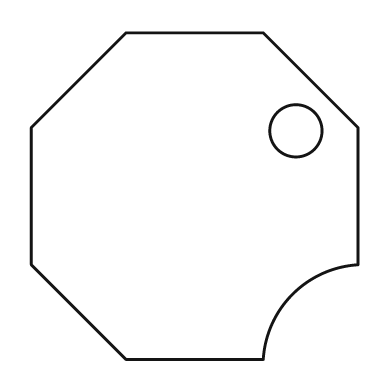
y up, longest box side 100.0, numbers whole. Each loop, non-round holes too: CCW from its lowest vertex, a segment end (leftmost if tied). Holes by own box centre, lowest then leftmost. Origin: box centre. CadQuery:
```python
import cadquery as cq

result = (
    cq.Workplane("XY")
    .moveTo(-21.0, -50.0)
    .lineTo(21.0, -50.0)
    .threePointArc((30.0, -30.0), (50.0, -21.0))
    .lineTo(50.0, 21.0)
    .lineTo(21.0, 50.0)
    .lineTo(-21.0, 50.0)
    .lineTo(-50.0, 21.0)
    .lineTo(-50.0, -21.0)
    .close()
    .moveTo(31.0, 20.0)
    .circle(8.0)
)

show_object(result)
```